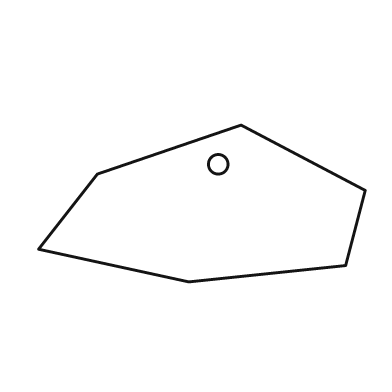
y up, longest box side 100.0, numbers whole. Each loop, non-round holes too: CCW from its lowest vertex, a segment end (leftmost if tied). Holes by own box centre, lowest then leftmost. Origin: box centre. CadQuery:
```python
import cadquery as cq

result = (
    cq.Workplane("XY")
    .moveTo(-4.0, -24.0)
    .lineTo(44.0, -19.0)
    .lineTo(50.0, 4.0)
    .lineTo(12.0, 24.0)
    .lineTo(-32.0, 9.0)
    .lineTo(-50.0, -14.0)
    .close()
    .moveTo(5.0, 12.0)
    .circle(3.0)
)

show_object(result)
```